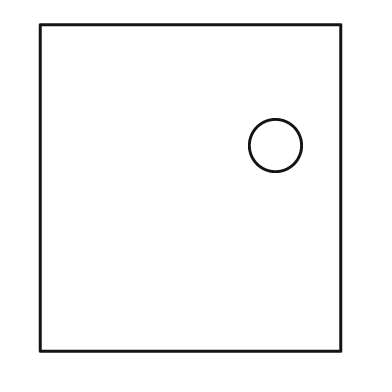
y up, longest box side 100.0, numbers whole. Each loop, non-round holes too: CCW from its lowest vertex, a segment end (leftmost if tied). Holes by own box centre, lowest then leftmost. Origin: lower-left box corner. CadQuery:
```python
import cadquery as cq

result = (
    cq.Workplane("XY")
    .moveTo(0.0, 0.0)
    .lineTo(92.0, 0.0)
    .lineTo(92.0, 100.0)
    .lineTo(0.0, 100.0)
    .close()
    .moveTo(72.0, 63.0)
    .circle(8.0)
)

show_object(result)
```